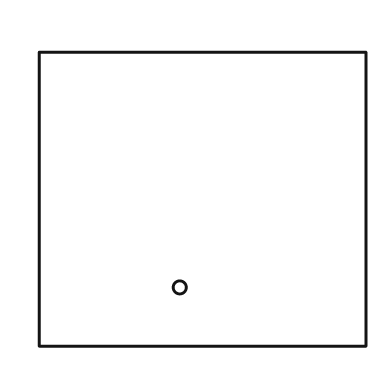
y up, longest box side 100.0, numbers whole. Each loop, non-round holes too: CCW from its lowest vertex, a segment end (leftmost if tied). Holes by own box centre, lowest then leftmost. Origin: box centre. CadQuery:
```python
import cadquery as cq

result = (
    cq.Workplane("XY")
    .moveTo(-50.0, -45.0)
    .lineTo(50.0, -45.0)
    .lineTo(50.0, 45.0)
    .lineTo(-50.0, 45.0)
    .close()
    .moveTo(-7.0, -27.0)
    .circle(2.0)
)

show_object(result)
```